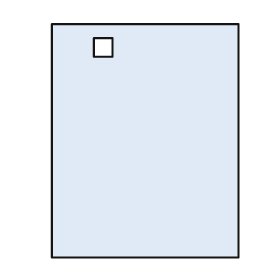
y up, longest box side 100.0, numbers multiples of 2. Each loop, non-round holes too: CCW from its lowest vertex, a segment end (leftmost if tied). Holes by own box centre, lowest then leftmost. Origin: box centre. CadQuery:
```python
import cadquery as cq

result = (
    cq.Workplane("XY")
    .moveTo(-40.0, -50.0)
    .lineTo(40.0, -50.0)
    .lineTo(40.0, 50.0)
    .lineTo(-40.0, 50.0)
    .close()
    .moveTo(-22.0, 36.0)
    .lineTo(-14.0, 36.0)
    .lineTo(-14.0, 44.0)
    .lineTo(-22.0, 44.0)
    .close()
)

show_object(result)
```